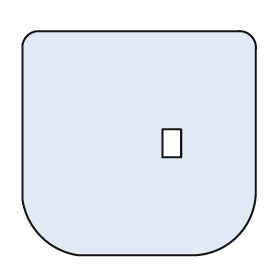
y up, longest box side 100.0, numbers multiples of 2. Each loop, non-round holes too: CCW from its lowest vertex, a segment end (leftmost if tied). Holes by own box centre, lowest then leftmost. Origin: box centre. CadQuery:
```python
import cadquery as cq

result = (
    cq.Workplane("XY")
    .moveTo(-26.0, -48.0)
    .lineTo(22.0, -48.0)
    .threePointArc((42.0, -40.0), (50.0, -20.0))
    .lineTo(50.0, 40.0)
    .threePointArc((48.0, 46.0), (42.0, 48.0))
    .lineTo(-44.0, 48.0)
    .threePointArc((-48.0, 46.0), (-50.0, 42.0))
    .lineTo(-50.0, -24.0)
    .threePointArc((-42.0, -40.0), (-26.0, -48.0))
    .close()
    .moveTo(10.0, -6.0)
    .lineTo(18.0, -6.0)
    .lineTo(18.0, 6.0)
    .lineTo(10.0, 6.0)
    .close()
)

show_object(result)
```